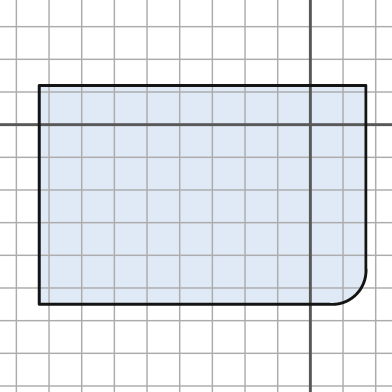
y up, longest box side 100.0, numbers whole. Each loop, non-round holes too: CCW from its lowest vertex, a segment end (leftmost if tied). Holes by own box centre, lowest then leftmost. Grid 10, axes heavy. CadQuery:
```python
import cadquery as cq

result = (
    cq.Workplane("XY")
    .moveTo(-83.0, -55.0)
    .lineTo(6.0, -55.0)
    .threePointArc((14.0, -52.0), (17.0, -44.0))
    .lineTo(17.0, 12.0)
    .lineTo(-83.0, 12.0)
    .close()
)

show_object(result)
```